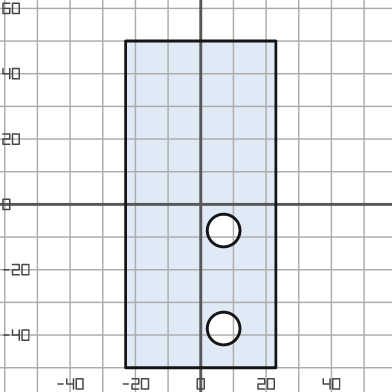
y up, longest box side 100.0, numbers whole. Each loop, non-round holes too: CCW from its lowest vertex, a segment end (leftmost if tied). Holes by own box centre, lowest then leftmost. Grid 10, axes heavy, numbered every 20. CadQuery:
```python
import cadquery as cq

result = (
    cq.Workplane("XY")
    .moveTo(-23.0, -50.0)
    .lineTo(23.0, -50.0)
    .lineTo(23.0, 50.0)
    .lineTo(-23.0, 50.0)
    .close()
    .moveTo(7.0, -38.0)
    .circle(5.0)
    .moveTo(7.0, -8.0)
    .circle(5.0)
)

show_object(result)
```